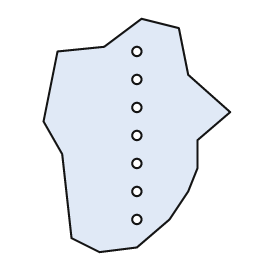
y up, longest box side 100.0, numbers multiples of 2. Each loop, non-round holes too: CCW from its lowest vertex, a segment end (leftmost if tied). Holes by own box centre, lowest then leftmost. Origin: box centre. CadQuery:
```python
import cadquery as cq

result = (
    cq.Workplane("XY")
    .moveTo(-16.0, -50.0)
    .lineTo(0.0, -48.0)
    .lineTo(14.0, -36.0)
    .lineTo(22.0, -24.0)
    .lineTo(26.0, -14.0)
    .lineTo(26.0, -2.0)
    .lineTo(40.0, 10.0)
    .lineTo(22.0, 26.0)
    .lineTo(18.0, 46.0)
    .lineTo(2.0, 50.0)
    .lineTo(-14.0, 38.0)
    .lineTo(-34.0, 36.0)
    .lineTo(-40.0, 6.0)
    .lineTo(-32.0, -8.0)
    .lineTo(-28.0, -44.0)
    .close()
    .moveTo(0.0, -36.0)
    .circle(2.0)
    .moveTo(0.0, -24.0)
    .circle(2.0)
    .moveTo(0.0, -12.0)
    .circle(2.0)
    .moveTo(0.0, 0.0)
    .circle(2.0)
    .moveTo(0.0, 12.0)
    .circle(2.0)
    .moveTo(0.0, 24.0)
    .circle(2.0)
    .moveTo(0.0, 36.0)
    .circle(2.0)
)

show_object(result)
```